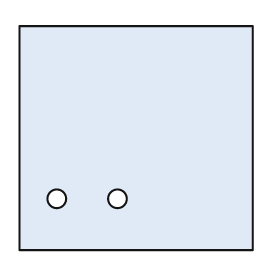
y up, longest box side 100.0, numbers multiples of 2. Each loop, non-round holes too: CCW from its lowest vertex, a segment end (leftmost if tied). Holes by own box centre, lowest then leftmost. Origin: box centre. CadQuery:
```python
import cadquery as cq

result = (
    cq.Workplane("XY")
    .moveTo(-50.0, -48.0)
    .lineTo(50.0, -48.0)
    .lineTo(50.0, 48.0)
    .lineTo(-50.0, 48.0)
    .close()
    .moveTo(-34.0, -26.0)
    .circle(4.0)
    .moveTo(-8.0, -26.0)
    .circle(4.0)
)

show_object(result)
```